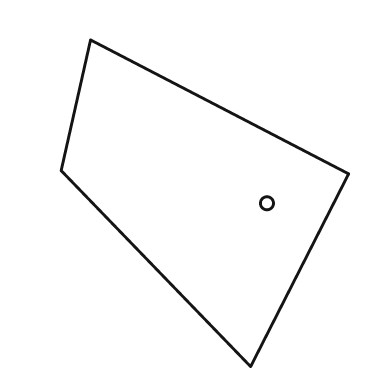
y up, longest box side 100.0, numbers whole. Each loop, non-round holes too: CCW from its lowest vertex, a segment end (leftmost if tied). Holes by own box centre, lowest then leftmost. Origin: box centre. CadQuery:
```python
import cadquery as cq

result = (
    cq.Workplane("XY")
    .moveTo(14.0, -50.0)
    .lineTo(44.0, 9.0)
    .lineTo(-35.0, 50.0)
    .lineTo(-44.0, 10.0)
    .close()
    .moveTo(19.0, 0.0)
    .circle(2.0)
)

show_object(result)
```